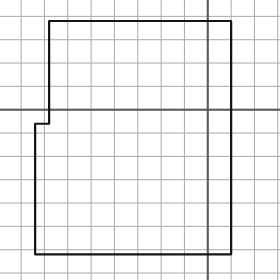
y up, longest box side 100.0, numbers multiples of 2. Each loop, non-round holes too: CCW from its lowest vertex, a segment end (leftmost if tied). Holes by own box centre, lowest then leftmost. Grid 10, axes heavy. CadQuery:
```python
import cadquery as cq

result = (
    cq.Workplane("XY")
    .moveTo(-74.0, -62.0)
    .lineTo(10.0, -62.0)
    .lineTo(10.0, 38.0)
    .lineTo(-68.0, 38.0)
    .lineTo(-68.0, -6.0)
    .lineTo(-74.0, -6.0)
    .close()
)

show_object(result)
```